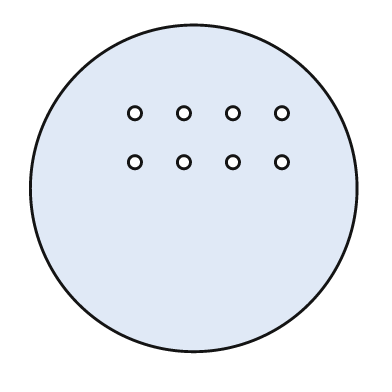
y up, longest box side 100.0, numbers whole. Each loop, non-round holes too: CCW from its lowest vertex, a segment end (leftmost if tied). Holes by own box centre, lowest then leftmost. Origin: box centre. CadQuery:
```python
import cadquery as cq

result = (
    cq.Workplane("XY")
    .moveTo(0.0, 0.0)
    .circle(50.0)
    .moveTo(-18.0, 8.0)
    .circle(2.0)
    .moveTo(-3.0, 8.0)
    .circle(2.0)
    .moveTo(12.0, 8.0)
    .circle(2.0)
    .moveTo(27.0, 8.0)
    .circle(2.0)
    .moveTo(-18.0, 23.0)
    .circle(2.0)
    .moveTo(-3.0, 23.0)
    .circle(2.0)
    .moveTo(12.0, 23.0)
    .circle(2.0)
    .moveTo(27.0, 23.0)
    .circle(2.0)
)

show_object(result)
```